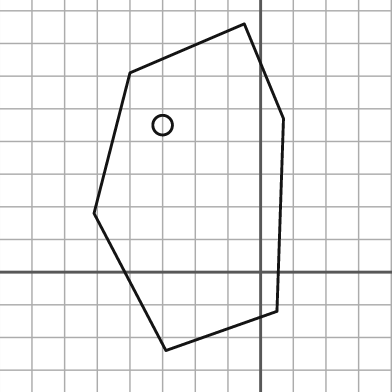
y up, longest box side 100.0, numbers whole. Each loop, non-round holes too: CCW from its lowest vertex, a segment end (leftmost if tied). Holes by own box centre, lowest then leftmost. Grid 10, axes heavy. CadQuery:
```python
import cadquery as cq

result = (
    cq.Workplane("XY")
    .moveTo(-29.0, -24.0)
    .lineTo(5.0, -12.0)
    .lineTo(7.0, 47.0)
    .lineTo(-5.0, 76.0)
    .lineTo(-40.0, 61.0)
    .lineTo(-51.0, 18.0)
    .close()
    .moveTo(-30.0, 45.0)
    .circle(3.0)
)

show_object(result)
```